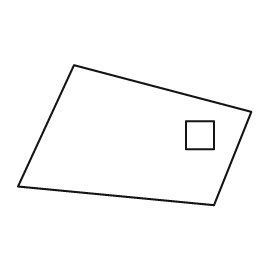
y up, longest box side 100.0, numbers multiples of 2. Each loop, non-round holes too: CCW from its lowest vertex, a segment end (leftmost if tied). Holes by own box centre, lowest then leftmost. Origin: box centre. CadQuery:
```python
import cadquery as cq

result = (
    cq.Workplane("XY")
    .moveTo(34.0, -30.0)
    .lineTo(50.0, 10.0)
    .lineTo(-26.0, 30.0)
    .lineTo(-50.0, -22.0)
    .close()
    .moveTo(22.0, -6.0)
    .lineTo(34.0, -6.0)
    .lineTo(34.0, 6.0)
    .lineTo(22.0, 6.0)
    .close()
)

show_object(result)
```